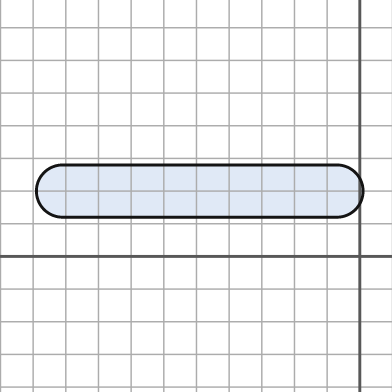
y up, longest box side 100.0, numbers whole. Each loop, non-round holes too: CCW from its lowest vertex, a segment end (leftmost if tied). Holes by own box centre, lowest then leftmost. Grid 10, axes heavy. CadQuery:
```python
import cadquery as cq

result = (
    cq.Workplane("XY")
    .moveTo(-91.0, 12.0)
    .lineTo(-7.0, 12.0)
    .threePointArc((1.0, 20.0), (-7.0, 28.0))
    .lineTo(-91.0, 28.0)
    .threePointArc((-99.0, 20.0), (-91.0, 12.0))
    .close()
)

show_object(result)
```